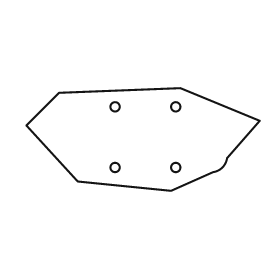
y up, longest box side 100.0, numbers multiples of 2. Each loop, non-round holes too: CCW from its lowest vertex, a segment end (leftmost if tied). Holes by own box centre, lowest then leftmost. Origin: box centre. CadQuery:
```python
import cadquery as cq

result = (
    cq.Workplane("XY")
    .moveTo(12.0, -22.0)
    .lineTo(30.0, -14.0)
    .threePointArc((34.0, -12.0), (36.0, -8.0))
    .lineTo(50.0, 8.0)
    .lineTo(16.0, 22.0)
    .lineTo(-36.0, 20.0)
    .lineTo(-50.0, 6.0)
    .lineTo(-28.0, -18.0)
    .close()
    .moveTo(-12.0, -12.0)
    .circle(2.0)
    .moveTo(14.0, -12.0)
    .circle(2.0)
    .moveTo(-12.0, 14.0)
    .circle(2.0)
    .moveTo(14.0, 14.0)
    .circle(2.0)
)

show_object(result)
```